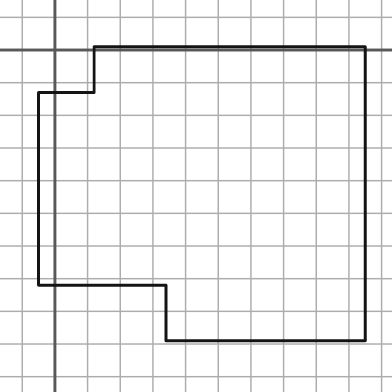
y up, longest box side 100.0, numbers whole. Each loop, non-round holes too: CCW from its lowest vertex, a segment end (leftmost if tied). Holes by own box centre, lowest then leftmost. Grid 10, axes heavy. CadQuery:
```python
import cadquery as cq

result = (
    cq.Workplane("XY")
    .moveTo(34.0, -89.0)
    .lineTo(95.0, -89.0)
    .lineTo(95.0, 1.0)
    .lineTo(12.0, 1.0)
    .lineTo(12.0, -13.0)
    .lineTo(-5.0, -13.0)
    .lineTo(-5.0, -72.0)
    .lineTo(34.0, -72.0)
    .close()
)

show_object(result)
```